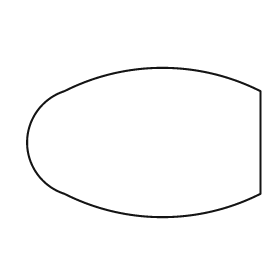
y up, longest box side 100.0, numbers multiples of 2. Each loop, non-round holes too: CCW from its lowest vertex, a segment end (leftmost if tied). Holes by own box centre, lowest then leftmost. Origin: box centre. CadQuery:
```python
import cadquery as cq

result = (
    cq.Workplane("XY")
    .moveTo(-34.0, -22.0)
    .threePointArc((8.0, -32.0), (50.0, -22.0))
    .lineTo(50.0, 22.0)
    .threePointArc((8.0, 32.0), (-34.0, 22.0))
    .threePointArc((-50.0, 0.0), (-34.0, -22.0))
    .close()
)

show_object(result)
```